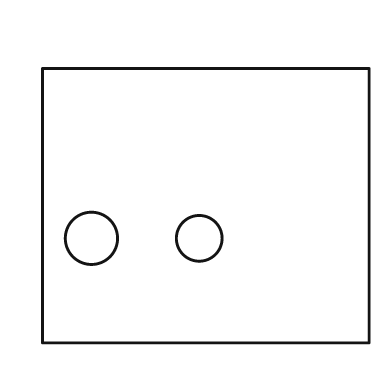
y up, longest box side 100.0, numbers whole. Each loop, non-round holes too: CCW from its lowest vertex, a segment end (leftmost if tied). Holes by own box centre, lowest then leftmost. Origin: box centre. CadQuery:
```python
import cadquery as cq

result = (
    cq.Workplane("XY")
    .moveTo(-50.0, -42.0)
    .lineTo(50.0, -42.0)
    .lineTo(50.0, 42.0)
    .lineTo(-50.0, 42.0)
    .close()
    .moveTo(-35.0, -10.0)
    .circle(8.0)
    .moveTo(-2.0, -10.0)
    .circle(7.0)
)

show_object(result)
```